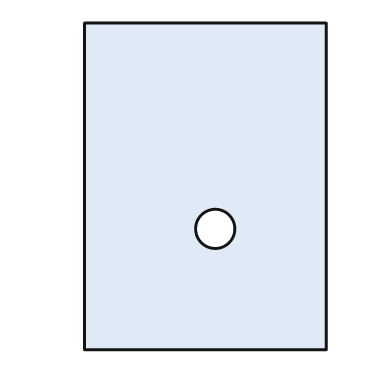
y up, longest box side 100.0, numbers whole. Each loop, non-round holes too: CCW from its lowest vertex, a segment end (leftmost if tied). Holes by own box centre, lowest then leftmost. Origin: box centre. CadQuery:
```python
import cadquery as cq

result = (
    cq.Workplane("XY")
    .moveTo(-37.0, -50.0)
    .lineTo(37.0, -50.0)
    .lineTo(37.0, 50.0)
    .lineTo(-37.0, 50.0)
    .close()
    .moveTo(3.0, -13.0)
    .circle(6.0)
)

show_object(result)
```